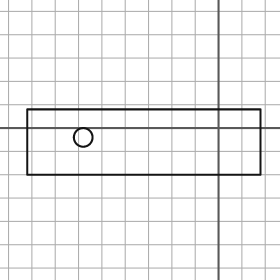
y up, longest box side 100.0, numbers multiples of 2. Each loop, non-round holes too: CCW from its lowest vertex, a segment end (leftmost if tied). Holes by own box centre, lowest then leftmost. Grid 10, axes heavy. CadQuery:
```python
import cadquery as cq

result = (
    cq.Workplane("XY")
    .moveTo(-82.0, -20.0)
    .lineTo(18.0, -20.0)
    .lineTo(18.0, 8.0)
    .lineTo(-82.0, 8.0)
    .close()
    .moveTo(-58.0, -4.0)
    .circle(4.0)
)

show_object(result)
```